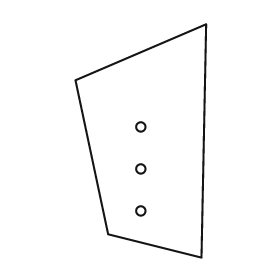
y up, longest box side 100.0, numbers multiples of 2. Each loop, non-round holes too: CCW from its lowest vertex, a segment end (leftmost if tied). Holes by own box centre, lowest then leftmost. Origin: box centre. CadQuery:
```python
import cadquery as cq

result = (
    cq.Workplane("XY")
    .moveTo(26.0, -50.0)
    .lineTo(28.0, 50.0)
    .lineTo(-28.0, 26.0)
    .lineTo(-14.0, -40.0)
    .close()
    .moveTo(0.0, -30.0)
    .circle(2.0)
    .moveTo(0.0, -12.0)
    .circle(2.0)
    .moveTo(0.0, 6.0)
    .circle(2.0)
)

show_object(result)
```